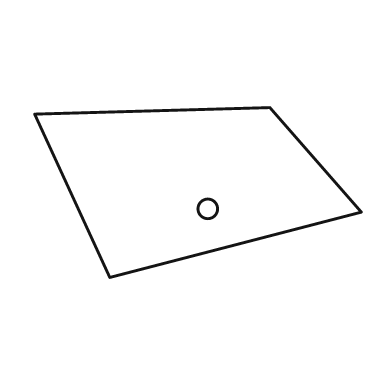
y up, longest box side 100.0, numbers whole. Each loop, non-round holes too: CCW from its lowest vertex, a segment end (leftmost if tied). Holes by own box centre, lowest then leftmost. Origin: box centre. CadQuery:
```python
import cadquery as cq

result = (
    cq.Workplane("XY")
    .moveTo(-27.0, -26.0)
    .lineTo(50.0, -6.0)
    .lineTo(22.0, 26.0)
    .lineTo(-50.0, 24.0)
    .close()
    .moveTo(3.0, -5.0)
    .circle(3.0)
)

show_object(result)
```